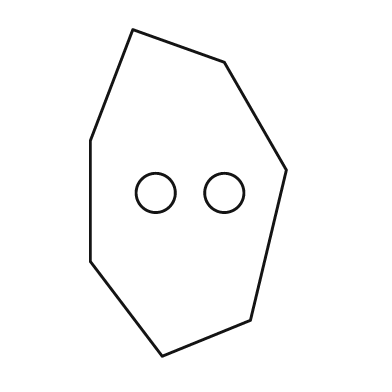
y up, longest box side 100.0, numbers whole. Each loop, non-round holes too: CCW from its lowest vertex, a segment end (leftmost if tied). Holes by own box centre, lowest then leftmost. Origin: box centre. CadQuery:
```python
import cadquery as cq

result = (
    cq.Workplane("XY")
    .moveTo(-8.0, -50.0)
    .lineTo(19.0, -39.0)
    .lineTo(30.0, 7.0)
    .lineTo(11.0, 40.0)
    .lineTo(-17.0, 50.0)
    .lineTo(-30.0, 16.0)
    .lineTo(-30.0, -21.0)
    .close()
    .moveTo(-10.0, 0.0)
    .circle(6.0)
    .moveTo(11.0, 0.0)
    .circle(6.0)
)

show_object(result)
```